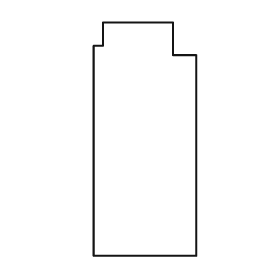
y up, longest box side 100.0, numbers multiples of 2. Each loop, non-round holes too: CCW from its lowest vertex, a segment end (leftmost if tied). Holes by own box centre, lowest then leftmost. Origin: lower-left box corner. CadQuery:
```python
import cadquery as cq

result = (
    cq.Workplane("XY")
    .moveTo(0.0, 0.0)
    .lineTo(44.0, 0.0)
    .lineTo(44.0, 86.0)
    .lineTo(34.0, 86.0)
    .lineTo(34.0, 100.0)
    .lineTo(4.0, 100.0)
    .lineTo(4.0, 90.0)
    .lineTo(0.0, 90.0)
    .close()
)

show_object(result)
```